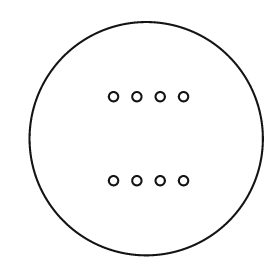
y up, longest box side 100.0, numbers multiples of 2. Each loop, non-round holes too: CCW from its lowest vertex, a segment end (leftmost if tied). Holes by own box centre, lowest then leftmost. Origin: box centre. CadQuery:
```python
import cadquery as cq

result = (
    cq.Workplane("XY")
    .moveTo(0.0, 0.0)
    .circle(50.0)
    .moveTo(-14.0, -18.0)
    .circle(2.0)
    .moveTo(-4.0, -18.0)
    .circle(2.0)
    .moveTo(6.0, -18.0)
    .circle(2.0)
    .moveTo(16.0, -18.0)
    .circle(2.0)
    .moveTo(-14.0, 18.0)
    .circle(2.0)
    .moveTo(-4.0, 18.0)
    .circle(2.0)
    .moveTo(6.0, 18.0)
    .circle(2.0)
    .moveTo(16.0, 18.0)
    .circle(2.0)
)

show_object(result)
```